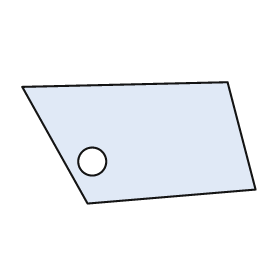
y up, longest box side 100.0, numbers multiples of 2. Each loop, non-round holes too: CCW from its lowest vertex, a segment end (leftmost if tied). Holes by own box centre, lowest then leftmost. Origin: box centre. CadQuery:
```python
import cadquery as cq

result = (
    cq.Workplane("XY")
    .moveTo(-22.0, -26.0)
    .lineTo(50.0, -20.0)
    .lineTo(38.0, 26.0)
    .lineTo(-50.0, 24.0)
    .close()
    .moveTo(-20.0, -8.0)
    .circle(6.0)
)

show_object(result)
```